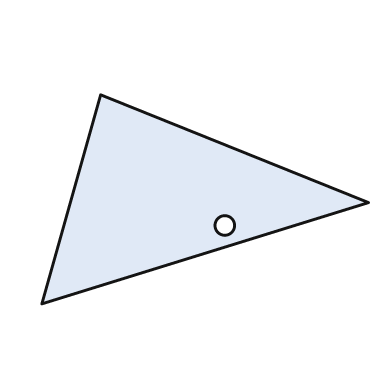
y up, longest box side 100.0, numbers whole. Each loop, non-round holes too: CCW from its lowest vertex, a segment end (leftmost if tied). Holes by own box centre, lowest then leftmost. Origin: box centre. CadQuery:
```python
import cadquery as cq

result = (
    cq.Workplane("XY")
    .moveTo(-50.0, -32.0)
    .lineTo(50.0, -1.0)
    .lineTo(-32.0, 32.0)
    .close()
    .moveTo(6.0, -8.0)
    .circle(3.0)
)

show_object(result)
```